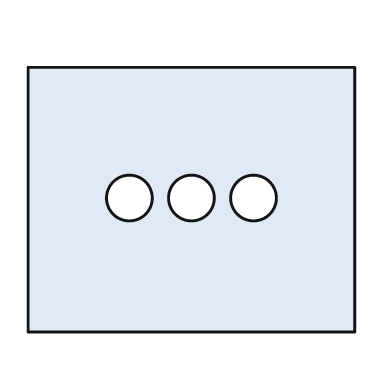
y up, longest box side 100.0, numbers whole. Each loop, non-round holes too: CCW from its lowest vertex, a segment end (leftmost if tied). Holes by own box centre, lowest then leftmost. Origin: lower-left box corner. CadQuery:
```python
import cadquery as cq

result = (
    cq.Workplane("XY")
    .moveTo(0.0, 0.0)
    .lineTo(100.0, 0.0)
    .lineTo(100.0, 81.0)
    .lineTo(0.0, 81.0)
    .close()
    .moveTo(31.0, 41.0)
    .circle(7.0)
    .moveTo(50.0, 41.0)
    .circle(7.0)
    .moveTo(69.0, 41.0)
    .circle(7.0)
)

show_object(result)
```